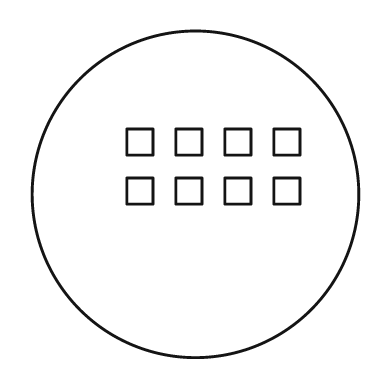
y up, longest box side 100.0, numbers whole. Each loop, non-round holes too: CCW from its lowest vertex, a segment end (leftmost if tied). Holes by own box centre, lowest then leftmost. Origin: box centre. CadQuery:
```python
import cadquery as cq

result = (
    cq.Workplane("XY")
    .moveTo(0.0, 0.0)
    .circle(50.0)
    .moveTo(-21.0, -3.0)
    .lineTo(-13.0, -3.0)
    .lineTo(-13.0, 5.0)
    .lineTo(-21.0, 5.0)
    .close()
    .moveTo(-6.0, -3.0)
    .lineTo(2.0, -3.0)
    .lineTo(2.0, 5.0)
    .lineTo(-6.0, 5.0)
    .close()
    .moveTo(9.0, -3.0)
    .lineTo(17.0, -3.0)
    .lineTo(17.0, 5.0)
    .lineTo(9.0, 5.0)
    .close()
    .moveTo(24.0, -3.0)
    .lineTo(32.0, -3.0)
    .lineTo(32.0, 5.0)
    .lineTo(24.0, 5.0)
    .close()
    .moveTo(-21.0, 12.0)
    .lineTo(-13.0, 12.0)
    .lineTo(-13.0, 20.0)
    .lineTo(-21.0, 20.0)
    .close()
    .moveTo(-6.0, 12.0)
    .lineTo(2.0, 12.0)
    .lineTo(2.0, 20.0)
    .lineTo(-6.0, 20.0)
    .close()
    .moveTo(9.0, 12.0)
    .lineTo(17.0, 12.0)
    .lineTo(17.0, 20.0)
    .lineTo(9.0, 20.0)
    .close()
    .moveTo(24.0, 12.0)
    .lineTo(32.0, 12.0)
    .lineTo(32.0, 20.0)
    .lineTo(24.0, 20.0)
    .close()
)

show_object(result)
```